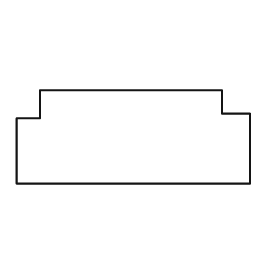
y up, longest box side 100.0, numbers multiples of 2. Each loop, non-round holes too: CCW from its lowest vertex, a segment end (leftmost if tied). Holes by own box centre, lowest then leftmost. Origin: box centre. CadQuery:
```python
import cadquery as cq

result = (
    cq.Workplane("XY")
    .moveTo(-50.0, -20.0)
    .lineTo(50.0, -20.0)
    .lineTo(50.0, 10.0)
    .lineTo(38.0, 10.0)
    .lineTo(38.0, 20.0)
    .lineTo(-40.0, 20.0)
    .lineTo(-40.0, 8.0)
    .lineTo(-50.0, 8.0)
    .close()
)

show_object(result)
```